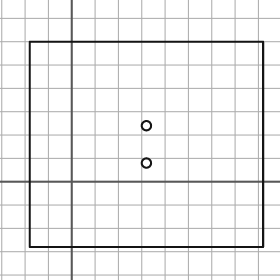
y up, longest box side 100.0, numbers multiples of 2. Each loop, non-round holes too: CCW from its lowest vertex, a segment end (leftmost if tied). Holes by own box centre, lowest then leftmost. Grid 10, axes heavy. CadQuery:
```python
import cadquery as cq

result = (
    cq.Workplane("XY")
    .moveTo(-18.0, -28.0)
    .lineTo(82.0, -28.0)
    .lineTo(82.0, 60.0)
    .lineTo(-18.0, 60.0)
    .close()
    .moveTo(32.0, 8.0)
    .circle(2.0)
    .moveTo(32.0, 24.0)
    .circle(2.0)
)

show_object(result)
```